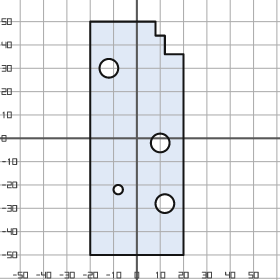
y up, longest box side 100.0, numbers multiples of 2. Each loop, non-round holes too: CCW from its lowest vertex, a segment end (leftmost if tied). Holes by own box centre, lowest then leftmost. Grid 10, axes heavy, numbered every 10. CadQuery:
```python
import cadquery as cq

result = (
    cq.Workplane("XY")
    .moveTo(-20.0, -50.0)
    .lineTo(20.0, -50.0)
    .lineTo(20.0, 36.0)
    .lineTo(12.0, 36.0)
    .lineTo(12.0, 44.0)
    .lineTo(8.0, 44.0)
    .lineTo(8.0, 50.0)
    .lineTo(-20.0, 50.0)
    .close()
    .moveTo(12.0, -28.0)
    .circle(4.0)
    .moveTo(-8.0, -22.0)
    .circle(2.0)
    .moveTo(10.0, -2.0)
    .circle(4.0)
    .moveTo(-12.0, 30.0)
    .circle(4.0)
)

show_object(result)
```